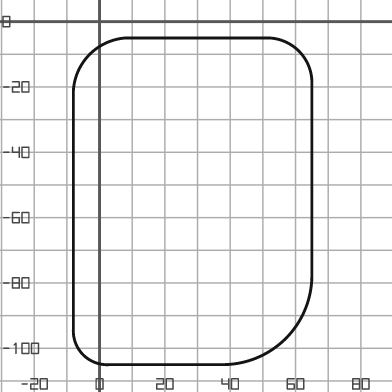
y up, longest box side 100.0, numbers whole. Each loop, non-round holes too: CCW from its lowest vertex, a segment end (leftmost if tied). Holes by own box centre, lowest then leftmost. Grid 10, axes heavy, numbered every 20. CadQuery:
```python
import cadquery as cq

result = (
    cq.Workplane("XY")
    .moveTo(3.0, -105.0)
    .lineTo(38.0, -105.0)
    .threePointArc((57.0, -97.0), (65.0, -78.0))
    .lineTo(65.0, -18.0)
    .threePointArc((61.0, -9.0), (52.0, -5.0))
    .lineTo(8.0, -5.0)
    .threePointArc((-3.0, -10.0), (-8.0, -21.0))
    .lineTo(-8.0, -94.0)
    .threePointArc((-5.0, -102.0), (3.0, -105.0))
    .close()
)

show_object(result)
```